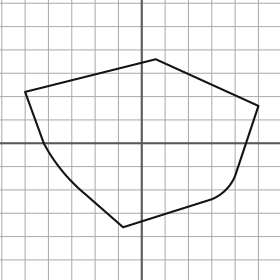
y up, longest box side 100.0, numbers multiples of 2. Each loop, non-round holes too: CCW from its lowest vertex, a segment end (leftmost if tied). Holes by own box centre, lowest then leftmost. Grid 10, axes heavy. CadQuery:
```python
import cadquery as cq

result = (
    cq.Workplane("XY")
    .moveTo(-8.0, -36.0)
    .lineTo(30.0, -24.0)
    .threePointArc((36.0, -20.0), (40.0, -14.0))
    .lineTo(50.0, 16.0)
    .lineTo(6.0, 36.0)
    .lineTo(-50.0, 22.0)
    .lineTo(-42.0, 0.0)
    .threePointArc((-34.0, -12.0), (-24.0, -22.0))
    .close()
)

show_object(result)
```